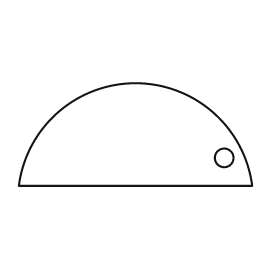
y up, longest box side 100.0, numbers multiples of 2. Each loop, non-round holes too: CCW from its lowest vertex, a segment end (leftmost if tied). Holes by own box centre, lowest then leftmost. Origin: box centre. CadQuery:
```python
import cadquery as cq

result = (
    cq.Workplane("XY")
    .moveTo(-50.0, -22.0)
    .lineTo(50.0, -22.0)
    .threePointArc((0.0, 22.0), (-50.0, -22.0))
    .close()
    .moveTo(38.0, -10.0)
    .circle(4.0)
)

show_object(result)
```